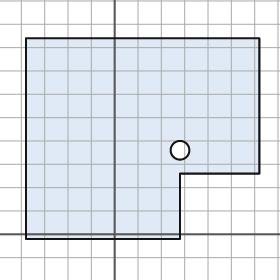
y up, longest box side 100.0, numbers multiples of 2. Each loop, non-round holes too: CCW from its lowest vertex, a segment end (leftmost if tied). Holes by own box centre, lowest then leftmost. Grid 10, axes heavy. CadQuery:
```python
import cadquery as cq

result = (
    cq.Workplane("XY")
    .moveTo(-38.0, -2.0)
    .lineTo(28.0, -2.0)
    .lineTo(28.0, 26.0)
    .lineTo(62.0, 26.0)
    .lineTo(62.0, 84.0)
    .lineTo(-38.0, 84.0)
    .close()
    .moveTo(28.0, 36.0)
    .circle(4.0)
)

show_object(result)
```